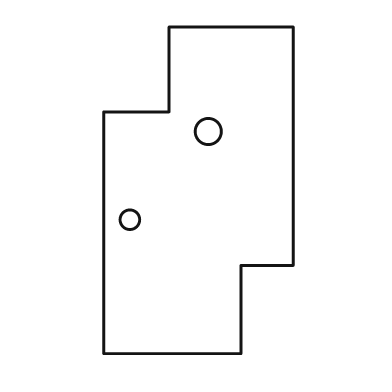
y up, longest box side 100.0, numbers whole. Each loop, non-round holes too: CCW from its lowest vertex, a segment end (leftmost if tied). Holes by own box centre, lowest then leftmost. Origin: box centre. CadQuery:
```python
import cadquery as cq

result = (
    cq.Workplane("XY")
    .moveTo(-29.0, -50.0)
    .lineTo(13.0, -50.0)
    .lineTo(13.0, -23.0)
    .lineTo(29.0, -23.0)
    .lineTo(29.0, 50.0)
    .lineTo(-9.0, 50.0)
    .lineTo(-9.0, 24.0)
    .lineTo(-29.0, 24.0)
    .close()
    .moveTo(-21.0, -9.0)
    .circle(3.0)
    .moveTo(3.0, 18.0)
    .circle(4.0)
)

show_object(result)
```